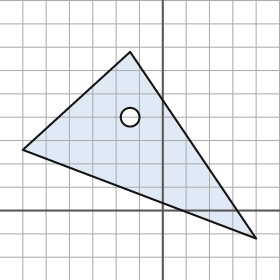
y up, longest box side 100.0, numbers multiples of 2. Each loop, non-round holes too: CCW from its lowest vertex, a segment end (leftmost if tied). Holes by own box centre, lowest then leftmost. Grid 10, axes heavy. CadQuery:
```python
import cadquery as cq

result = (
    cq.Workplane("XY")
    .moveTo(40.0, -12.0)
    .lineTo(-14.0, 68.0)
    .lineTo(-60.0, 26.0)
    .close()
    .moveTo(-14.0, 40.0)
    .circle(4.0)
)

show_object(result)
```